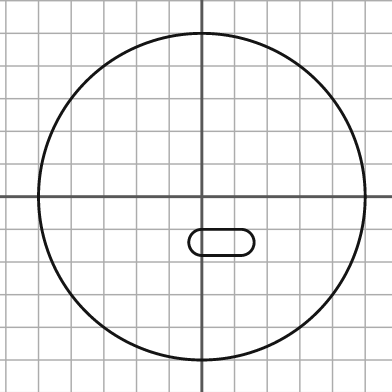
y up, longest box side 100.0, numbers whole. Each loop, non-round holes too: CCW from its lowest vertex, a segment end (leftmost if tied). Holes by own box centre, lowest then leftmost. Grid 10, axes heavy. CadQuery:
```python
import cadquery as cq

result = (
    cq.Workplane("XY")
    .moveTo(0.0, 0.0)
    .circle(50.0)
    .moveTo(0.0, -18.0)
    .lineTo(12.0, -18.0)
    .threePointArc((16.0, -14.0), (12.0, -10.0))
    .lineTo(0.0, -10.0)
    .threePointArc((-4.0, -14.0), (0.0, -18.0))
    .close()
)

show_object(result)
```